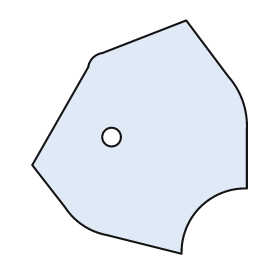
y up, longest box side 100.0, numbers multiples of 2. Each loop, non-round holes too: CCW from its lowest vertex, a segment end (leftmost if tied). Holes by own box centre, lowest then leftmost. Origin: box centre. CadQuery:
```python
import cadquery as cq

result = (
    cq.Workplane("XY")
    .moveTo(18.0, -50.0)
    .threePointArc((26.0, -30.0), (46.0, -22.0))
    .lineTo(46.0, 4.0)
    .threePointArc((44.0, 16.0), (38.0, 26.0))
    .lineTo(20.0, 50.0)
    .lineTo(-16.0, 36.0)
    .threePointArc((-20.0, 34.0), (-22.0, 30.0))
    .lineTo(-46.0, -12.0)
    .lineTo(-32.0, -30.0)
    .threePointArc((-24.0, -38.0), (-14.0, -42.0))
    .close()
    .moveTo(-12.0, 0.0)
    .circle(4.0)
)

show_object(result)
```